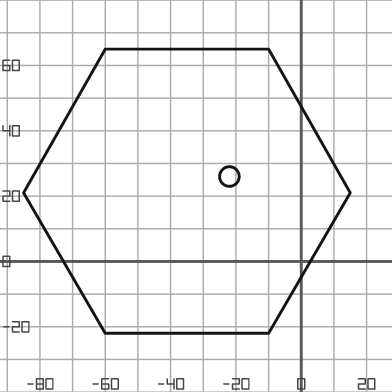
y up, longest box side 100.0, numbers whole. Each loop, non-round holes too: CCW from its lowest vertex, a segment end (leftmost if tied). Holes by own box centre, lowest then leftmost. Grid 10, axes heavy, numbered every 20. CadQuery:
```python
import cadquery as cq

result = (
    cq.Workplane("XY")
    .moveTo(-60.0, -22.0)
    .lineTo(-10.0, -22.0)
    .lineTo(15.0, 21.0)
    .lineTo(-10.0, 65.0)
    .lineTo(-60.0, 65.0)
    .lineTo(-85.0, 21.0)
    .close()
    .moveTo(-22.0, 26.0)
    .circle(3.0)
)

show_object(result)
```